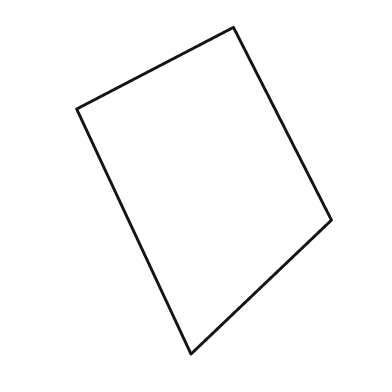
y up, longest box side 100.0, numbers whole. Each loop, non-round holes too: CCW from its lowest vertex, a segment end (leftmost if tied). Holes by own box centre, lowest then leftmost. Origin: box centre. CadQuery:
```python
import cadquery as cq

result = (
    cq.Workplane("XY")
    .moveTo(-4.0, -50.0)
    .lineTo(39.0, -9.0)
    .lineTo(9.0, 50.0)
    .lineTo(-39.0, 25.0)
    .close()
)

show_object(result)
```